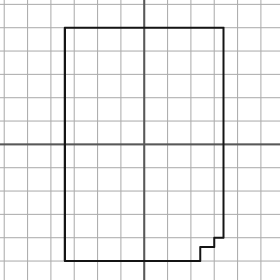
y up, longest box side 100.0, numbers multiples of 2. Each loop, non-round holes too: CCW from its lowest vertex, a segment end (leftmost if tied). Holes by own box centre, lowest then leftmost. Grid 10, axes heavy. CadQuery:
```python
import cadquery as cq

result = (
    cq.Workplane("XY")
    .moveTo(-34.0, -50.0)
    .lineTo(24.0, -50.0)
    .lineTo(24.0, -44.0)
    .lineTo(30.0, -44.0)
    .lineTo(30.0, -40.0)
    .lineTo(34.0, -40.0)
    .lineTo(34.0, 50.0)
    .lineTo(-34.0, 50.0)
    .close()
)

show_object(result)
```